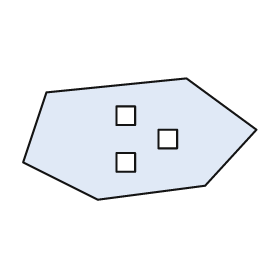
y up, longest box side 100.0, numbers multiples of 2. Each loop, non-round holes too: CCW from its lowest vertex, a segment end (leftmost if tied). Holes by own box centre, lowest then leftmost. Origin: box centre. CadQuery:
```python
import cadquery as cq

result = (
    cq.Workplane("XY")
    .moveTo(-18.0, -26.0)
    .lineTo(28.0, -20.0)
    .lineTo(50.0, 4.0)
    .lineTo(20.0, 26.0)
    .lineTo(-40.0, 20.0)
    .lineTo(-50.0, -10.0)
    .close()
    .moveTo(-10.0, -14.0)
    .lineTo(-2.0, -14.0)
    .lineTo(-2.0, -6.0)
    .lineTo(-10.0, -6.0)
    .close()
    .moveTo(8.0, -4.0)
    .lineTo(16.0, -4.0)
    .lineTo(16.0, 4.0)
    .lineTo(8.0, 4.0)
    .close()
    .moveTo(-10.0, 6.0)
    .lineTo(-2.0, 6.0)
    .lineTo(-2.0, 14.0)
    .lineTo(-10.0, 14.0)
    .close()
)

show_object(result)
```